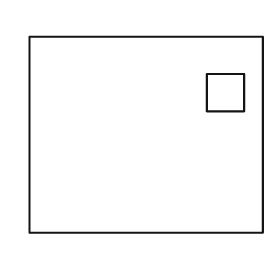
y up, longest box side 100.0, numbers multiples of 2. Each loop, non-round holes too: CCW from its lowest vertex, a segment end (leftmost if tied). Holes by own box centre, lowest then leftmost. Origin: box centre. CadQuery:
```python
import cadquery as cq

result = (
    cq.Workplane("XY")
    .moveTo(-50.0, -42.0)
    .lineTo(50.0, -42.0)
    .lineTo(50.0, 42.0)
    .lineTo(-50.0, 42.0)
    .close()
    .moveTo(26.0, 10.0)
    .lineTo(42.0, 10.0)
    .lineTo(42.0, 26.0)
    .lineTo(26.0, 26.0)
    .close()
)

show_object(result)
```